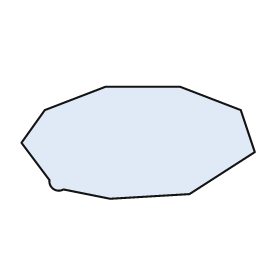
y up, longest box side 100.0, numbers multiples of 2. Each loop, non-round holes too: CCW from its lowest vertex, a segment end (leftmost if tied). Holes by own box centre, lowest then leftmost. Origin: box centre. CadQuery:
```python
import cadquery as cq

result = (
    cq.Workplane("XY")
    .moveTo(-12.0, -24.0)
    .lineTo(22.0, -22.0)
    .lineTo(50.0, -4.0)
    .lineTo(44.0, 14.0)
    .lineTo(18.0, 24.0)
    .lineTo(-14.0, 24.0)
    .lineTo(-40.0, 14.0)
    .lineTo(-50.0, 0.0)
    .lineTo(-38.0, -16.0)
    .threePointArc((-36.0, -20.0), (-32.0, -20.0))
    .close()
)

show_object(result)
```